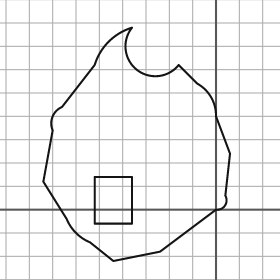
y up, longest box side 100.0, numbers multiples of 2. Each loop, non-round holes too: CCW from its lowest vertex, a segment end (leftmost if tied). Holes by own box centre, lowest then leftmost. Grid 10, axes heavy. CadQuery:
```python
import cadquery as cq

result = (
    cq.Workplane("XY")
    .moveTo(-44.0, -22.0)
    .lineTo(-24.0, -18.0)
    .lineTo(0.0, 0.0)
    .threePointArc((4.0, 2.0), (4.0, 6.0))
    .lineTo(6.0, 24.0)
    .lineTo(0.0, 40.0)
    .threePointArc((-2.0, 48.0), (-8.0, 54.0))
    .lineTo(-16.0, 62.0)
    .threePointArc((-34.0, 60.0), (-36.0, 78.0))
    .threePointArc((-46.0, 72.0), (-52.0, 62.0))
    .lineTo(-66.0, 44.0)
    .threePointArc((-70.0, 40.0), (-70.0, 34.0))
    .lineTo(-74.0, 12.0)
    .lineTo(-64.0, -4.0)
    .threePointArc((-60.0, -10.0), (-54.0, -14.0))
    .close()
    .moveTo(-52.0, -6.0)
    .lineTo(-36.0, -6.0)
    .lineTo(-36.0, 14.0)
    .lineTo(-52.0, 14.0)
    .close()
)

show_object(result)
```